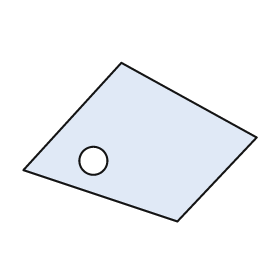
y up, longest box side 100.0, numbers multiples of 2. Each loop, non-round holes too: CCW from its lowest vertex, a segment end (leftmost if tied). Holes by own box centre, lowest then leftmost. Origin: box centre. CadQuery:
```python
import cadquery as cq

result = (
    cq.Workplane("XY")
    .moveTo(16.0, -34.0)
    .lineTo(50.0, 2.0)
    .lineTo(-8.0, 34.0)
    .lineTo(-50.0, -12.0)
    .close()
    .moveTo(-20.0, -8.0)
    .circle(6.0)
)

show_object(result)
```